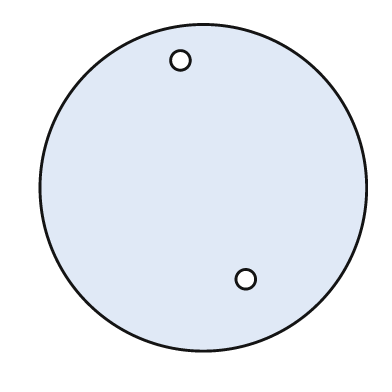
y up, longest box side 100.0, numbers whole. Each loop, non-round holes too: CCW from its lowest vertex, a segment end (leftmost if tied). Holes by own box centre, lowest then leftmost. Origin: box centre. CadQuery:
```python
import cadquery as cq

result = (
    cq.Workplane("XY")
    .moveTo(0.0, 0.0)
    .circle(50.0)
    .moveTo(13.0, -28.0)
    .circle(3.0)
    .moveTo(-7.0, 39.0)
    .circle(3.0)
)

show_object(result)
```